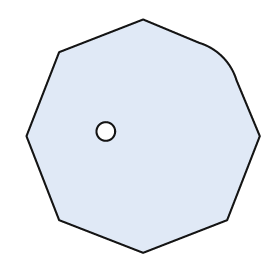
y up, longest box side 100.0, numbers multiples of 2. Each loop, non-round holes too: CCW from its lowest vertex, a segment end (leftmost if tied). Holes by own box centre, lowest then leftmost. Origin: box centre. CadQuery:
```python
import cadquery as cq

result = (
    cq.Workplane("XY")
    .moveTo(0.0, -50.0)
    .lineTo(36.0, -36.0)
    .lineTo(50.0, 0.0)
    .lineTo(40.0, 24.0)
    .threePointArc((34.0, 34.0), (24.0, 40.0))
    .lineTo(0.0, 50.0)
    .lineTo(-36.0, 36.0)
    .lineTo(-50.0, 0.0)
    .lineTo(-36.0, -36.0)
    .close()
    .moveTo(-16.0, 2.0)
    .circle(4.0)
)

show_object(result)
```